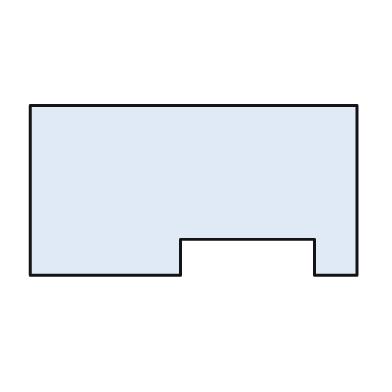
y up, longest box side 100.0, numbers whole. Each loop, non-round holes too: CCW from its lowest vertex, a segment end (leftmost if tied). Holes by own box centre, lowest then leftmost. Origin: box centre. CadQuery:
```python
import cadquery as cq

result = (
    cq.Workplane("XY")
    .moveTo(-50.0, -26.0)
    .lineTo(-4.0, -26.0)
    .lineTo(-4.0, -15.0)
    .lineTo(37.0, -15.0)
    .lineTo(37.0, -26.0)
    .lineTo(50.0, -26.0)
    .lineTo(50.0, 26.0)
    .lineTo(-50.0, 26.0)
    .close()
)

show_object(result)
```